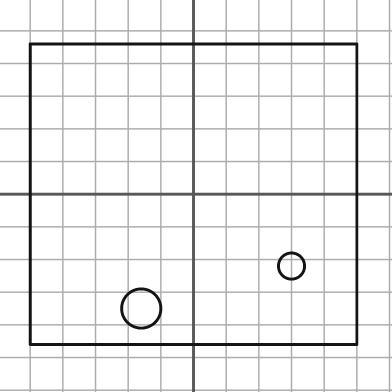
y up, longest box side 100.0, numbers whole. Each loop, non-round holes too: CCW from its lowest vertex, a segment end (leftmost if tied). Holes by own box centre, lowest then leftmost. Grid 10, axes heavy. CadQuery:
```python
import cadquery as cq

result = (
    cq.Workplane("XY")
    .moveTo(-50.0, -46.0)
    .lineTo(50.0, -46.0)
    .lineTo(50.0, 46.0)
    .lineTo(-50.0, 46.0)
    .close()
    .moveTo(-16.0, -35.0)
    .circle(6.0)
    .moveTo(30.0, -22.0)
    .circle(4.0)
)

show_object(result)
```